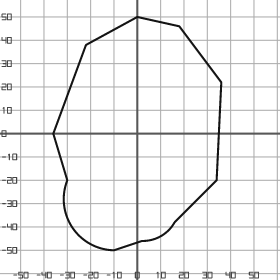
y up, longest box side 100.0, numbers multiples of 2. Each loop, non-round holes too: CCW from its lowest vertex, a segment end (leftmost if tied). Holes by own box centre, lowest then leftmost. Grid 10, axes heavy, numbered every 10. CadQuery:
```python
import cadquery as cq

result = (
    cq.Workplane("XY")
    .moveTo(-10.0, -50.0)
    .lineTo(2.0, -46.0)
    .threePointArc((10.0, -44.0), (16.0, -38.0))
    .lineTo(34.0, -20.0)
    .lineTo(36.0, 22.0)
    .lineTo(18.0, 46.0)
    .lineTo(0.0, 50.0)
    .lineTo(-22.0, 38.0)
    .lineTo(-36.0, 0.0)
    .lineTo(-30.0, -20.0)
    .threePointArc((-28.0, -40.0), (-10.0, -50.0))
    .close()
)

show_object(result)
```